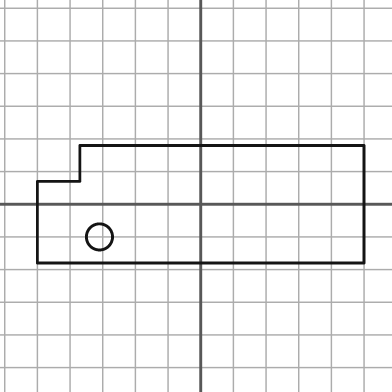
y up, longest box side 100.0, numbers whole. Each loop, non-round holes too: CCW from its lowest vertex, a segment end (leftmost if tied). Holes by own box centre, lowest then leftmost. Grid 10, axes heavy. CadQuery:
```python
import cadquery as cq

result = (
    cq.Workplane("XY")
    .moveTo(-50.0, -18.0)
    .lineTo(50.0, -18.0)
    .lineTo(50.0, 18.0)
    .lineTo(-37.0, 18.0)
    .lineTo(-37.0, 7.0)
    .lineTo(-50.0, 7.0)
    .close()
    .moveTo(-31.0, -10.0)
    .circle(4.0)
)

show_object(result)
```